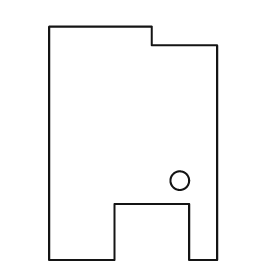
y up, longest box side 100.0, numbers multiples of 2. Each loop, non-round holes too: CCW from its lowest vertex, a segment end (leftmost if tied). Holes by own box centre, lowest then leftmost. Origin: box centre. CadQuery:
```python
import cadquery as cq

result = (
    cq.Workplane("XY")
    .moveTo(-36.0, -50.0)
    .lineTo(-8.0, -50.0)
    .lineTo(-8.0, -26.0)
    .lineTo(24.0, -26.0)
    .lineTo(24.0, -50.0)
    .lineTo(36.0, -50.0)
    .lineTo(36.0, 42.0)
    .lineTo(8.0, 42.0)
    .lineTo(8.0, 50.0)
    .lineTo(-36.0, 50.0)
    .close()
    .moveTo(20.0, -16.0)
    .circle(4.0)
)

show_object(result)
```